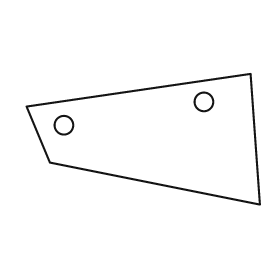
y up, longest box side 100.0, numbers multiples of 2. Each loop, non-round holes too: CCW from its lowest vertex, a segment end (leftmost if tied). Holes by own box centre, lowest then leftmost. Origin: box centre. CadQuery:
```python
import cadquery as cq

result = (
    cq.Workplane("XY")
    .moveTo(50.0, -28.0)
    .lineTo(46.0, 28.0)
    .lineTo(-50.0, 14.0)
    .lineTo(-40.0, -10.0)
    .close()
    .moveTo(-34.0, 6.0)
    .circle(4.0)
    .moveTo(26.0, 16.0)
    .circle(4.0)
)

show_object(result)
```